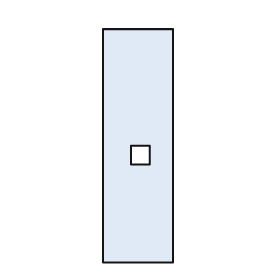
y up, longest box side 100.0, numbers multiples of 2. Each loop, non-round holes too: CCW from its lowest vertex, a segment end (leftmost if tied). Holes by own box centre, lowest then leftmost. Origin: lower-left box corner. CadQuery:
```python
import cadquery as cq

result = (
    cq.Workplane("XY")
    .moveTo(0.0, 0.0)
    .lineTo(30.0, 0.0)
    .lineTo(30.0, 100.0)
    .lineTo(0.0, 100.0)
    .close()
    .moveTo(12.0, 42.0)
    .lineTo(20.0, 42.0)
    .lineTo(20.0, 50.0)
    .lineTo(12.0, 50.0)
    .close()
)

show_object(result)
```